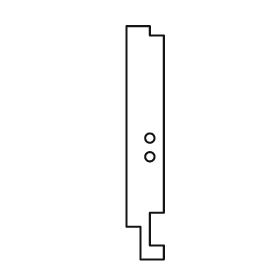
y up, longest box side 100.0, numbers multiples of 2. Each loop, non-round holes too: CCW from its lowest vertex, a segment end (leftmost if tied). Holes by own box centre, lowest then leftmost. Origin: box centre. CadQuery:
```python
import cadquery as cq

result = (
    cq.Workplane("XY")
    .moveTo(-2.0, -50.0)
    .lineTo(8.0, -50.0)
    .lineTo(8.0, -44.0)
    .lineTo(2.0, -44.0)
    .lineTo(2.0, -30.0)
    .lineTo(8.0, -30.0)
    .lineTo(8.0, 46.0)
    .lineTo(2.0, 46.0)
    .lineTo(2.0, 50.0)
    .lineTo(-8.0, 50.0)
    .lineTo(-8.0, -36.0)
    .lineTo(-2.0, -36.0)
    .close()
    .moveTo(2.0, -6.0)
    .circle(2.0)
    .moveTo(2.0, 2.0)
    .circle(2.0)
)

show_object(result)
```